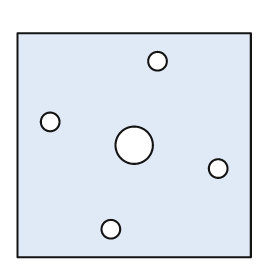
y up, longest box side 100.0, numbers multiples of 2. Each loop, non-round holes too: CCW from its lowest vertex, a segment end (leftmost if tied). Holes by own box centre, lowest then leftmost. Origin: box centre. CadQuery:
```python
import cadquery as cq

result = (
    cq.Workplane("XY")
    .moveTo(-50.0, -48.0)
    .lineTo(50.0, -48.0)
    .lineTo(50.0, 48.0)
    .lineTo(-50.0, 48.0)
    .close()
    .moveTo(-10.0, -36.0)
    .circle(4.0)
    .moveTo(36.0, -10.0)
    .circle(4.0)
    .moveTo(0.0, 0.0)
    .circle(8.0)
    .moveTo(-36.0, 10.0)
    .circle(4.0)
    .moveTo(10.0, 36.0)
    .circle(4.0)
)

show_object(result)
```